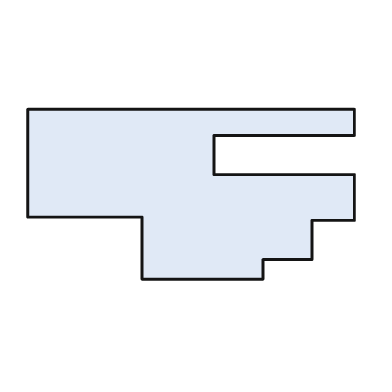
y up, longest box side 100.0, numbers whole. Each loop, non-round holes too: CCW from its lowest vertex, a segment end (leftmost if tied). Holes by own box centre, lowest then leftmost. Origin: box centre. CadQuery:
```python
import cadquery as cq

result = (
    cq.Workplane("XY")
    .moveTo(-15.0, -26.0)
    .lineTo(22.0, -26.0)
    .lineTo(22.0, -20.0)
    .lineTo(37.0, -20.0)
    .lineTo(37.0, -8.0)
    .lineTo(50.0, -8.0)
    .lineTo(50.0, 6.0)
    .lineTo(7.0, 6.0)
    .lineTo(7.0, 18.0)
    .lineTo(50.0, 18.0)
    .lineTo(50.0, 26.0)
    .lineTo(-50.0, 26.0)
    .lineTo(-50.0, -7.0)
    .lineTo(-15.0, -7.0)
    .close()
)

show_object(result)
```